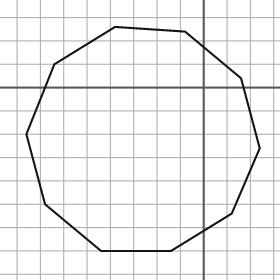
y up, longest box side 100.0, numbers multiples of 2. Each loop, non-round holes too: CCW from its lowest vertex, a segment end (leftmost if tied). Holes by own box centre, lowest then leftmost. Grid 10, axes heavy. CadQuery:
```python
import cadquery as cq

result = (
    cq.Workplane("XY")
    .moveTo(-44.0, -70.0)
    .lineTo(-14.0, -70.0)
    .lineTo(12.0, -54.0)
    .lineTo(24.0, -26.0)
    .lineTo(16.0, 4.0)
    .lineTo(-8.0, 24.0)
    .lineTo(-38.0, 26.0)
    .lineTo(-64.0, 10.0)
    .lineTo(-76.0, -20.0)
    .lineTo(-68.0, -50.0)
    .close()
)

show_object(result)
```